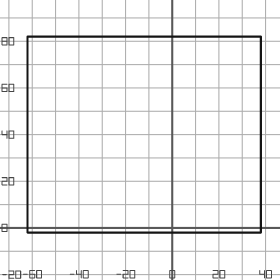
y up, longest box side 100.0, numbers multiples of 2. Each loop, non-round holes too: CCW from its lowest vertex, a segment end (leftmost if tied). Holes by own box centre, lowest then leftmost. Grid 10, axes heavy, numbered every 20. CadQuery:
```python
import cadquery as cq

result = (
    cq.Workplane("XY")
    .moveTo(-62.0, -2.0)
    .lineTo(38.0, -2.0)
    .lineTo(38.0, 82.0)
    .lineTo(-62.0, 82.0)
    .close()
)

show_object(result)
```